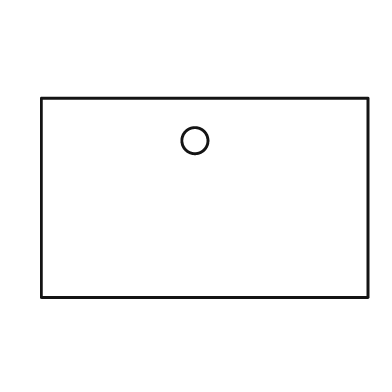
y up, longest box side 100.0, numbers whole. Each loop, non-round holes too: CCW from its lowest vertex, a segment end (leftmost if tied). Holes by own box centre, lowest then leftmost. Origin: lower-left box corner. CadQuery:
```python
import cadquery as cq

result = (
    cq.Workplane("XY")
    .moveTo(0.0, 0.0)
    .lineTo(100.0, 0.0)
    .lineTo(100.0, 61.0)
    .lineTo(0.0, 61.0)
    .close()
    .moveTo(47.0, 48.0)
    .circle(4.0)
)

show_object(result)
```